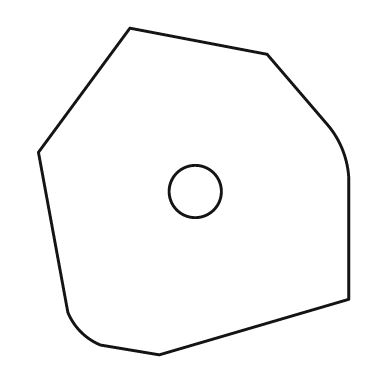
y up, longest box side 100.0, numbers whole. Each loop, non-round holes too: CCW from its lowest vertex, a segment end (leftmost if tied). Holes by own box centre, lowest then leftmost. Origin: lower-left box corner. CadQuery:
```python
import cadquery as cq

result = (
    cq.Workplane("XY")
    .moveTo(37.0, 0.0)
    .lineTo(95.0, 17.0)
    .lineTo(95.0, 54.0)
    .threePointArc((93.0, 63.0), (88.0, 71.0))
    .lineTo(70.0, 92.0)
    .lineTo(28.0, 100.0)
    .lineTo(0.0, 62.0)
    .lineTo(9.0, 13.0)
    .threePointArc((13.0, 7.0), (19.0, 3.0))
    .close()
    .moveTo(48.0, 50.0)
    .circle(8.0)
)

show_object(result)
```